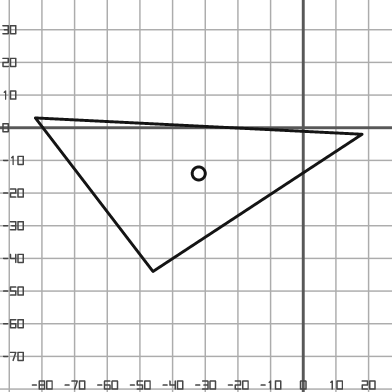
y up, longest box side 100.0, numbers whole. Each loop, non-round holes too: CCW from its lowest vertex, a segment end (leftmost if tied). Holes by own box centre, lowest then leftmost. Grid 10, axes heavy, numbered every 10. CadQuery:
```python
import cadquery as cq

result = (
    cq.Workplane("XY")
    .moveTo(-46.0, -44.0)
    .lineTo(18.0, -2.0)
    .lineTo(-82.0, 3.0)
    .close()
    .moveTo(-32.0, -14.0)
    .circle(2.0)
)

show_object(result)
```